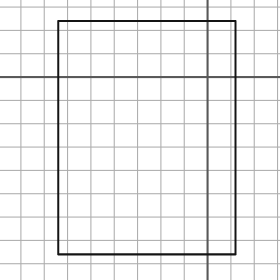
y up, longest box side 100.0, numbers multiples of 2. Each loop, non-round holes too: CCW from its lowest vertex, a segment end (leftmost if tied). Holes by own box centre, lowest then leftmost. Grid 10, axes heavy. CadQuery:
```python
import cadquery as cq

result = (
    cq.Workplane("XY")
    .moveTo(-64.0, -76.0)
    .lineTo(12.0, -76.0)
    .lineTo(12.0, 24.0)
    .lineTo(-64.0, 24.0)
    .close()
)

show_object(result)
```